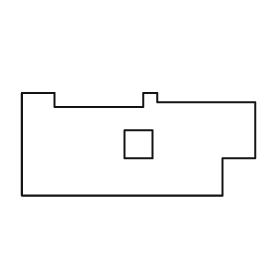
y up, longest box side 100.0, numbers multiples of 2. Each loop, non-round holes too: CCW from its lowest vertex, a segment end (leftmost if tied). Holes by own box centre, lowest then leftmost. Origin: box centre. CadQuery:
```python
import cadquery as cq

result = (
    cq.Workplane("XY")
    .moveTo(-50.0, -22.0)
    .lineTo(36.0, -22.0)
    .lineTo(36.0, -6.0)
    .lineTo(50.0, -6.0)
    .lineTo(50.0, 18.0)
    .lineTo(8.0, 18.0)
    .lineTo(8.0, 22.0)
    .lineTo(2.0, 22.0)
    .lineTo(2.0, 16.0)
    .lineTo(-36.0, 16.0)
    .lineTo(-36.0, 22.0)
    .lineTo(-50.0, 22.0)
    .close()
    .moveTo(-6.0, -6.0)
    .lineTo(6.0, -6.0)
    .lineTo(6.0, 6.0)
    .lineTo(-6.0, 6.0)
    .close()
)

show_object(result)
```